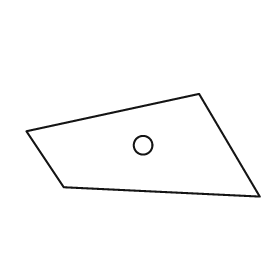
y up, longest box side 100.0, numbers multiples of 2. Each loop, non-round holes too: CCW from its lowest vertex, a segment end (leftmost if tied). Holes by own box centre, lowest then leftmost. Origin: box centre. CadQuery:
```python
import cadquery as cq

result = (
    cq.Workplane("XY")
    .moveTo(50.0, -22.0)
    .lineTo(24.0, 22.0)
    .lineTo(-50.0, 6.0)
    .lineTo(-34.0, -18.0)
    .close()
    .moveTo(0.0, 0.0)
    .circle(4.0)
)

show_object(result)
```